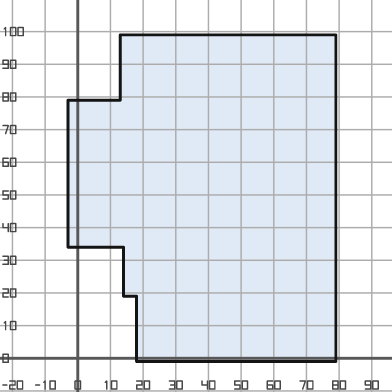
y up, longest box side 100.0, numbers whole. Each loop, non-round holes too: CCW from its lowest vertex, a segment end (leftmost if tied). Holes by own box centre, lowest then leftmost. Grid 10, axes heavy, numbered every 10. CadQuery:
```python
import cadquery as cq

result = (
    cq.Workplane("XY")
    .moveTo(18.0, -1.0)
    .lineTo(79.0, -1.0)
    .lineTo(79.0, 99.0)
    .lineTo(13.0, 99.0)
    .lineTo(13.0, 79.0)
    .lineTo(-3.0, 79.0)
    .lineTo(-3.0, 34.0)
    .lineTo(14.0, 34.0)
    .lineTo(14.0, 19.0)
    .lineTo(18.0, 19.0)
    .close()
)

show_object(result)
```